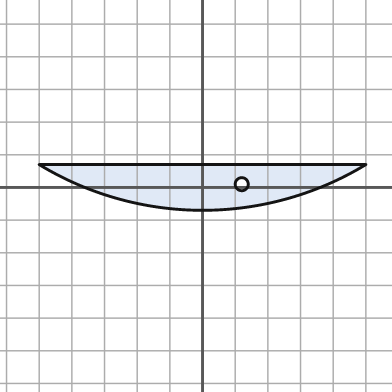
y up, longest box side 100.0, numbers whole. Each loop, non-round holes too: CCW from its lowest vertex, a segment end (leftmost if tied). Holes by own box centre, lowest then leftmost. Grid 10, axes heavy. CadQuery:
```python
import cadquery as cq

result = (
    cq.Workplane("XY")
    .moveTo(-50.0, 7.0)
    .threePointArc((0.0, -7.0), (50.0, 7.0))
    .close()
    .moveTo(12.0, 1.0)
    .circle(2.0)
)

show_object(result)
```